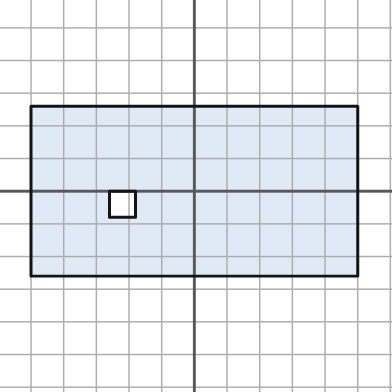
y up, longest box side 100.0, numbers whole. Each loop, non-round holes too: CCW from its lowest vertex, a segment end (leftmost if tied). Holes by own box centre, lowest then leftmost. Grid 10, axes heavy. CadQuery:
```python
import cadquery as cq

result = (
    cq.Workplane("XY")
    .moveTo(-50.0, -26.0)
    .lineTo(50.0, -26.0)
    .lineTo(50.0, 26.0)
    .lineTo(-50.0, 26.0)
    .close()
    .moveTo(-26.0, -8.0)
    .lineTo(-18.0, -8.0)
    .lineTo(-18.0, 0.0)
    .lineTo(-26.0, 0.0)
    .close()
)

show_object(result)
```